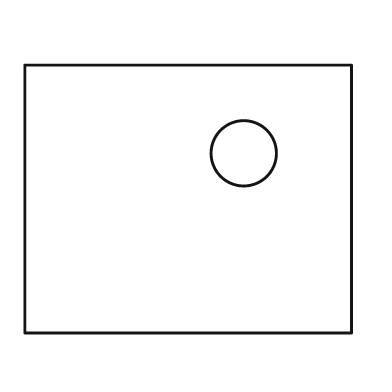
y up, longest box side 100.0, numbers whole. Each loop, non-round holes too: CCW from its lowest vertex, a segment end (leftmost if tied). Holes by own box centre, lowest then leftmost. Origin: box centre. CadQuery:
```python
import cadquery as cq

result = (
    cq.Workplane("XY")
    .moveTo(-50.0, -41.0)
    .lineTo(50.0, -41.0)
    .lineTo(50.0, 41.0)
    .lineTo(-50.0, 41.0)
    .close()
    .moveTo(17.0, 14.0)
    .circle(10.0)
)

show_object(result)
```